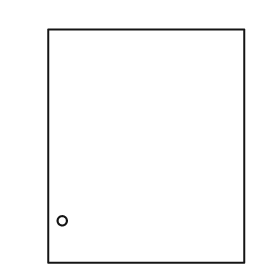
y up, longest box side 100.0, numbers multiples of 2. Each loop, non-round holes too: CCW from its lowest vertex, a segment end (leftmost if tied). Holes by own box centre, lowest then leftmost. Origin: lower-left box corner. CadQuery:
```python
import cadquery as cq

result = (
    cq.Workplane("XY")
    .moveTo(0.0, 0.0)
    .lineTo(84.0, 0.0)
    .lineTo(84.0, 100.0)
    .lineTo(0.0, 100.0)
    .close()
    .moveTo(6.0, 18.0)
    .circle(2.0)
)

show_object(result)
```